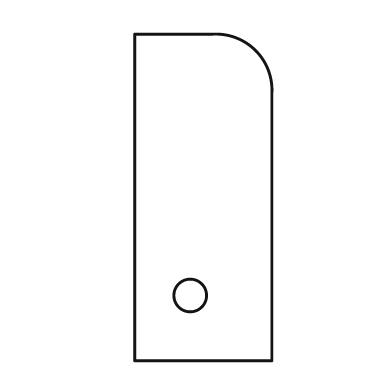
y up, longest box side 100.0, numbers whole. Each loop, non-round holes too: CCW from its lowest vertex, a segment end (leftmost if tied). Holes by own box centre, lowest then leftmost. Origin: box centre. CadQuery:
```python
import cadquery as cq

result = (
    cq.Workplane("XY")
    .moveTo(-21.0, -50.0)
    .lineTo(21.0, -50.0)
    .lineTo(21.0, 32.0)
    .threePointArc((16.0, 45.0), (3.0, 50.0))
    .lineTo(-21.0, 50.0)
    .close()
    .moveTo(-4.0, -30.0)
    .circle(5.0)
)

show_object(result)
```